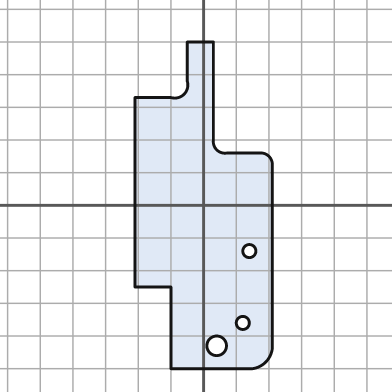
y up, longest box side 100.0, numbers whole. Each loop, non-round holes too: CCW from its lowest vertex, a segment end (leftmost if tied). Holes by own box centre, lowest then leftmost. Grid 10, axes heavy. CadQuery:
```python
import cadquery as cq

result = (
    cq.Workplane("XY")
    .moveTo(-10.0, -50.0)
    .lineTo(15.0, -50.0)
    .threePointArc((19.0, -48.0), (21.0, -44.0))
    .lineTo(21.0, 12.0)
    .threePointArc((20.0, 15.0), (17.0, 16.0))
    .lineTo(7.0, 16.0)
    .threePointArc((4.0, 17.0), (3.0, 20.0))
    .lineTo(3.0, 50.0)
    .lineTo(-5.0, 50.0)
    .lineTo(-5.0, 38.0)
    .threePointArc((-6.0, 34.0), (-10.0, 33.0))
    .lineTo(-21.0, 33.0)
    .lineTo(-21.0, -25.0)
    .lineTo(-10.0, -25.0)
    .close()
    .moveTo(4.0, -43.0)
    .circle(3.0)
    .moveTo(12.0, -36.0)
    .circle(2.0)
    .moveTo(14.0, -14.0)
    .circle(2.0)
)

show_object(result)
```